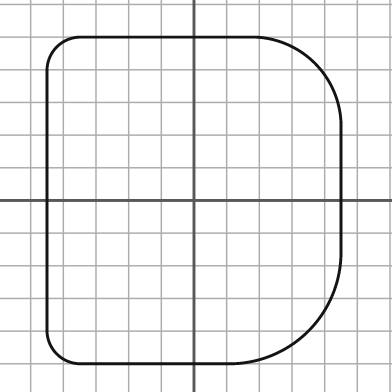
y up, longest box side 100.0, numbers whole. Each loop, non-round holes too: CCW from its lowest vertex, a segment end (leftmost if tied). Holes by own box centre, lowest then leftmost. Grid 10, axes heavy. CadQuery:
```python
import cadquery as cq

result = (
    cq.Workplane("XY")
    .moveTo(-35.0, -50.0)
    .lineTo(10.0, -50.0)
    .threePointArc((35.0, -40.0), (45.0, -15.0))
    .lineTo(45.0, 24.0)
    .threePointArc((37.0, 42.0), (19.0, 50.0))
    .lineTo(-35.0, 50.0)
    .threePointArc((-42.0, 47.0), (-45.0, 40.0))
    .lineTo(-45.0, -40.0)
    .threePointArc((-42.0, -47.0), (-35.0, -50.0))
    .close()
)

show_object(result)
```